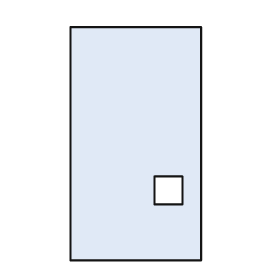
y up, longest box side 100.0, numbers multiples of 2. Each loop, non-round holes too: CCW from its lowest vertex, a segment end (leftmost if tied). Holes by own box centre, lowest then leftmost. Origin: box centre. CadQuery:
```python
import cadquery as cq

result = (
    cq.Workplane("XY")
    .moveTo(-28.0, -50.0)
    .lineTo(28.0, -50.0)
    .lineTo(28.0, 50.0)
    .lineTo(-28.0, 50.0)
    .close()
    .moveTo(8.0, -26.0)
    .lineTo(20.0, -26.0)
    .lineTo(20.0, -14.0)
    .lineTo(8.0, -14.0)
    .close()
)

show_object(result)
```